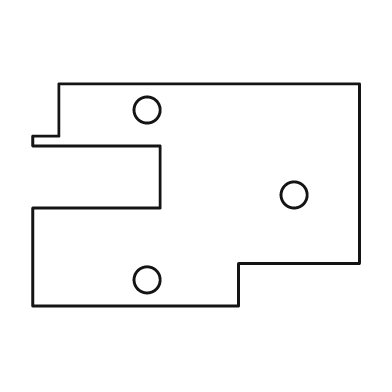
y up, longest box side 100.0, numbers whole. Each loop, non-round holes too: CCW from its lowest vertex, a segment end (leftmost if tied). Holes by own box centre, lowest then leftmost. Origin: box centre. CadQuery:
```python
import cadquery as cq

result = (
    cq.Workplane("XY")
    .moveTo(-50.0, -34.0)
    .lineTo(13.0, -34.0)
    .lineTo(13.0, -21.0)
    .lineTo(50.0, -21.0)
    .lineTo(50.0, 34.0)
    .lineTo(-42.0, 34.0)
    .lineTo(-42.0, 18.0)
    .lineTo(-50.0, 18.0)
    .lineTo(-50.0, 15.0)
    .lineTo(-11.0, 15.0)
    .lineTo(-11.0, -4.0)
    .lineTo(-50.0, -4.0)
    .close()
    .moveTo(-15.0, -26.0)
    .circle(4.0)
    .moveTo(30.0, 0.0)
    .circle(4.0)
    .moveTo(-15.0, 26.0)
    .circle(4.0)
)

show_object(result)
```